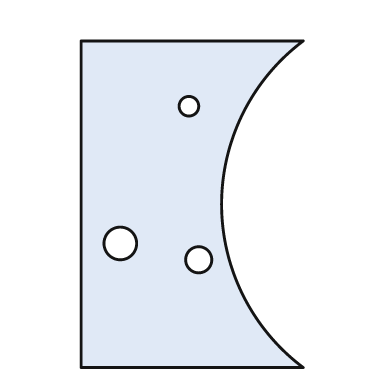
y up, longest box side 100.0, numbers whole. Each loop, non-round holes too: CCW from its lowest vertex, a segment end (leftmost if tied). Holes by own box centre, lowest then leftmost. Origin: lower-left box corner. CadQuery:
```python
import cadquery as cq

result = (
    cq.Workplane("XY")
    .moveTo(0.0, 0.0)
    .lineTo(68.0, 0.0)
    .threePointArc((43.0, 50.0), (68.0, 100.0))
    .lineTo(0.0, 100.0)
    .close()
    .moveTo(36.0, 33.0)
    .circle(4.0)
    .moveTo(12.0, 38.0)
    .circle(5.0)
    .moveTo(33.0, 80.0)
    .circle(3.0)
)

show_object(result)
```